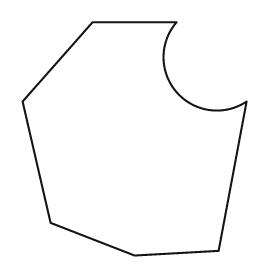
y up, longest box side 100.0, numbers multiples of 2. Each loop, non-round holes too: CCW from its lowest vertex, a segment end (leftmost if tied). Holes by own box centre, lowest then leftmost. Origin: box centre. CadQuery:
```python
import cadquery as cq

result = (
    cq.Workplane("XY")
    .moveTo(0.0, -50.0)
    .lineTo(36.0, -48.0)
    .lineTo(48.0, 16.0)
    .threePointArc((18.0, 20.0), (18.0, 50.0))
    .lineTo(-18.0, 50.0)
    .lineTo(-48.0, 16.0)
    .lineTo(-36.0, -36.0)
    .close()
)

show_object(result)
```